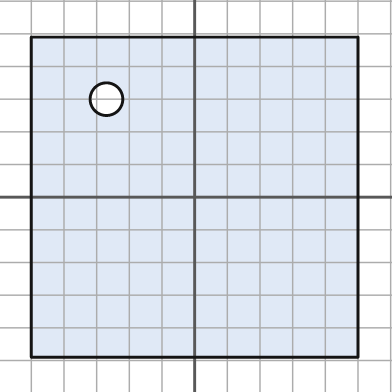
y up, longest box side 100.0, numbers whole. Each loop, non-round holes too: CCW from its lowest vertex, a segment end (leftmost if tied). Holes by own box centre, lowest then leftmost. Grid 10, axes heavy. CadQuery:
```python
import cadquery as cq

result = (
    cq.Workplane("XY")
    .moveTo(-50.0, -49.0)
    .lineTo(50.0, -49.0)
    .lineTo(50.0, 49.0)
    .lineTo(-50.0, 49.0)
    .close()
    .moveTo(-27.0, 30.0)
    .circle(5.0)
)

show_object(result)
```